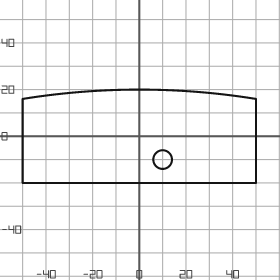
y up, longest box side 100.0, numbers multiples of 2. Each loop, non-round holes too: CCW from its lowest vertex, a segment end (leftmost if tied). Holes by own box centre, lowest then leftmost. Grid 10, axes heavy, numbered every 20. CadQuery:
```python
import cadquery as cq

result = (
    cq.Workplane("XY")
    .moveTo(-50.0, -20.0)
    .lineTo(50.0, -20.0)
    .lineTo(50.0, 16.0)
    .threePointArc((0.0, 20.0), (-50.0, 16.0))
    .close()
    .moveTo(10.0, -10.0)
    .circle(4.0)
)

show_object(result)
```